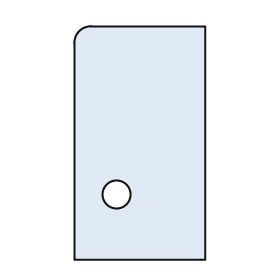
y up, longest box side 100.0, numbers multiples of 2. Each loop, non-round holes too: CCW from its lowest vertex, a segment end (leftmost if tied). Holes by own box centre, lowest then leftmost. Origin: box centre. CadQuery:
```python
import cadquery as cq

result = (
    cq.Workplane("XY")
    .moveTo(-28.0, -50.0)
    .lineTo(28.0, -50.0)
    .lineTo(28.0, 50.0)
    .lineTo(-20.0, 50.0)
    .threePointArc((-26.0, 48.0), (-28.0, 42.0))
    .close()
    .moveTo(-10.0, -22.0)
    .circle(6.0)
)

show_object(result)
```